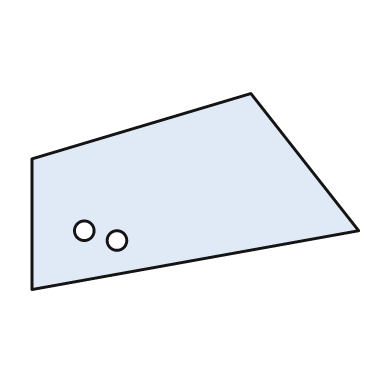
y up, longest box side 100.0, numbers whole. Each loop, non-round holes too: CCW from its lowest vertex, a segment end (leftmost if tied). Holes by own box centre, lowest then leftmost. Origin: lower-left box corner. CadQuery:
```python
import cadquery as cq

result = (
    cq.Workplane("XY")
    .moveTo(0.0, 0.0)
    .lineTo(100.0, 18.0)
    .lineTo(67.0, 60.0)
    .lineTo(0.0, 40.0)
    .close()
    .moveTo(26.0, 15.0)
    .circle(3.0)
    .moveTo(16.0, 18.0)
    .circle(3.0)
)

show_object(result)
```